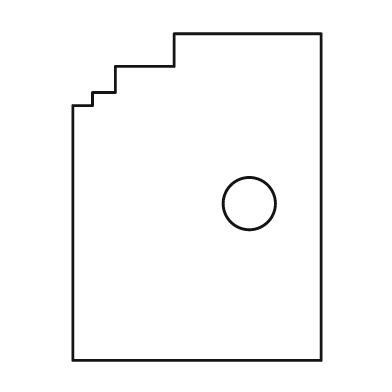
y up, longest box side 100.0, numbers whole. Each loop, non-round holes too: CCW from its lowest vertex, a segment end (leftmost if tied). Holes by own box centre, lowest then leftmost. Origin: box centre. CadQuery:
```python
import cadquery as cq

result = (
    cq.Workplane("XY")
    .moveTo(-38.0, -50.0)
    .lineTo(38.0, -50.0)
    .lineTo(38.0, 50.0)
    .lineTo(-7.0, 50.0)
    .lineTo(-7.0, 40.0)
    .lineTo(-25.0, 40.0)
    .lineTo(-25.0, 32.0)
    .lineTo(-32.0, 32.0)
    .lineTo(-32.0, 28.0)
    .lineTo(-38.0, 28.0)
    .close()
    .moveTo(16.0, -2.0)
    .circle(8.0)
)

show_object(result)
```